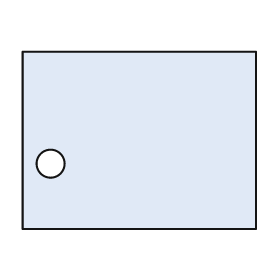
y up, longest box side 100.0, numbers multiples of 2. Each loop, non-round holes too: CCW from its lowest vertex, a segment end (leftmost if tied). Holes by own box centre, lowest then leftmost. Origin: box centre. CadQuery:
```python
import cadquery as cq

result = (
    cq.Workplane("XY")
    .moveTo(-50.0, -38.0)
    .lineTo(50.0, -38.0)
    .lineTo(50.0, 38.0)
    .lineTo(-50.0, 38.0)
    .close()
    .moveTo(-38.0, -10.0)
    .circle(6.0)
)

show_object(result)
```